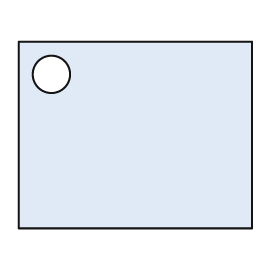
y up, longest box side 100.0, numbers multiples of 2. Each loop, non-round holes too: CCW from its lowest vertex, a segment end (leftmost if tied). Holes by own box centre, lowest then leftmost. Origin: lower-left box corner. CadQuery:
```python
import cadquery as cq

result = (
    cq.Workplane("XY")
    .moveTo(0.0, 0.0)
    .lineTo(100.0, 0.0)
    .lineTo(100.0, 80.0)
    .lineTo(0.0, 80.0)
    .close()
    .moveTo(14.0, 66.0)
    .circle(8.0)
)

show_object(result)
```